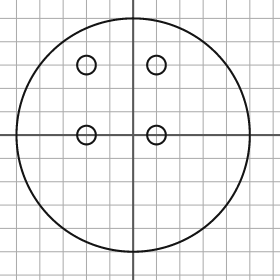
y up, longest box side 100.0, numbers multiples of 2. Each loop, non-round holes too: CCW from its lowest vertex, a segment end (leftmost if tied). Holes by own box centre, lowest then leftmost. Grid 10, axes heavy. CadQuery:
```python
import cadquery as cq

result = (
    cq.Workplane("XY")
    .moveTo(0.0, 0.0)
    .circle(50.0)
    .moveTo(-20.0, 0.0)
    .circle(4.0)
    .moveTo(10.0, 0.0)
    .circle(4.0)
    .moveTo(-20.0, 30.0)
    .circle(4.0)
    .moveTo(10.0, 30.0)
    .circle(4.0)
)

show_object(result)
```